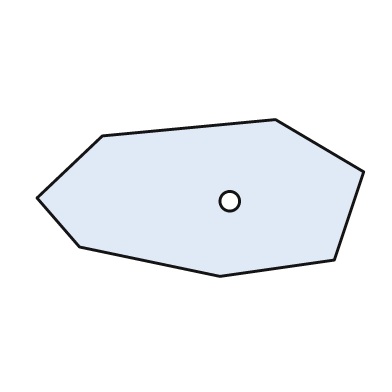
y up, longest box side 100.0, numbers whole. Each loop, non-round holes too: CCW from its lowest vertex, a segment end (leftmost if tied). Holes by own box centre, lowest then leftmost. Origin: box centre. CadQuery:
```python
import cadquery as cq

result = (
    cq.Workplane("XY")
    .moveTo(6.0, -24.0)
    .lineTo(41.0, -19.0)
    .lineTo(50.0, 8.0)
    .lineTo(23.0, 24.0)
    .lineTo(-30.0, 19.0)
    .lineTo(-50.0, 0.0)
    .lineTo(-37.0, -15.0)
    .close()
    .moveTo(9.0, -1.0)
    .circle(3.0)
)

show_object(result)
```